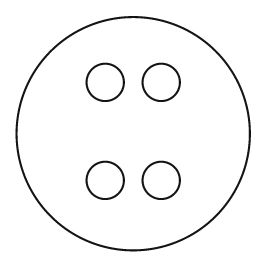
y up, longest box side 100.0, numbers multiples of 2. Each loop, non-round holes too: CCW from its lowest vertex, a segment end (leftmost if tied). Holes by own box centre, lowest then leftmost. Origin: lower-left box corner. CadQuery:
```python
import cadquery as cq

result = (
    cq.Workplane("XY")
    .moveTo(50.0, 50.0)
    .circle(50.0)
    .moveTo(38.0, 30.0)
    .circle(8.0)
    .moveTo(62.0, 30.0)
    .circle(8.0)
    .moveTo(38.0, 72.0)
    .circle(8.0)
    .moveTo(62.0, 72.0)
    .circle(8.0)
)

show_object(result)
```